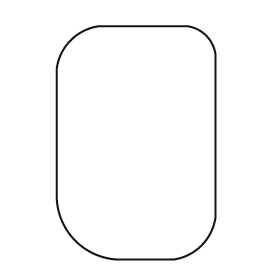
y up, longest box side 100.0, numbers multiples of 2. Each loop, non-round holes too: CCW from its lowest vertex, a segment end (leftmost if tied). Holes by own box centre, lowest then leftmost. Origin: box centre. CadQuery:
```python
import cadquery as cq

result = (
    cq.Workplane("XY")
    .moveTo(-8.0, -50.0)
    .lineTo(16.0, -50.0)
    .threePointArc((28.0, -44.0), (34.0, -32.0))
    .lineTo(34.0, 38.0)
    .threePointArc((30.0, 46.0), (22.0, 50.0))
    .lineTo(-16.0, 50.0)
    .threePointArc((-28.0, 44.0), (-34.0, 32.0))
    .lineTo(-34.0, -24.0)
    .threePointArc((-26.0, -42.0), (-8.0, -50.0))
    .close()
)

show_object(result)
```